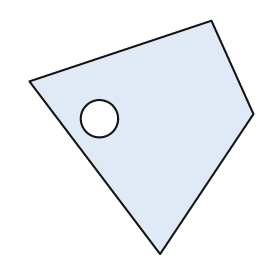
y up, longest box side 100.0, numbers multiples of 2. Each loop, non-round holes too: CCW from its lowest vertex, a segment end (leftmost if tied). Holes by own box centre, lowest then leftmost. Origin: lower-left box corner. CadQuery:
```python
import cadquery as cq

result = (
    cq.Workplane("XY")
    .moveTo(56.0, 0.0)
    .lineTo(96.0, 60.0)
    .lineTo(78.0, 100.0)
    .lineTo(0.0, 74.0)
    .close()
    .moveTo(30.0, 58.0)
    .circle(8.0)
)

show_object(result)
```